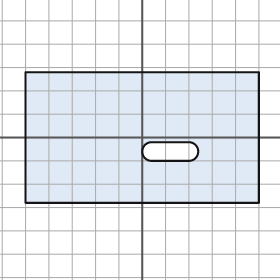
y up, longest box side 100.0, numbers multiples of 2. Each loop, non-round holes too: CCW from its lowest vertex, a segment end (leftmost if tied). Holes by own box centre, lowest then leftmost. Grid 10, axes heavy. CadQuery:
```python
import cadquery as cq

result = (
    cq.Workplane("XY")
    .moveTo(-50.0, -28.0)
    .lineTo(50.0, -28.0)
    .lineTo(50.0, 28.0)
    .lineTo(-50.0, 28.0)
    .close()
    .moveTo(4.0, -10.0)
    .lineTo(20.0, -10.0)
    .threePointArc((24.0, -6.0), (20.0, -2.0))
    .lineTo(4.0, -2.0)
    .threePointArc((0.0, -6.0), (4.0, -10.0))
    .close()
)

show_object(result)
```